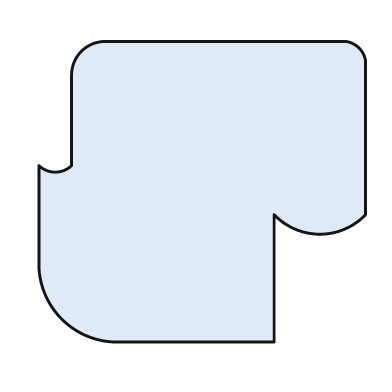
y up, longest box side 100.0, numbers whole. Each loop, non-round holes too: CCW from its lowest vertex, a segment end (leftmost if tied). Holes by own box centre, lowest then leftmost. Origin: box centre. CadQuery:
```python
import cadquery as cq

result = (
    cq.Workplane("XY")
    .moveTo(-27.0, -46.0)
    .lineTo(22.0, -46.0)
    .lineTo(22.0, -7.0)
    .threePointArc((36.0, -13.0), (50.0, -7.0))
    .lineTo(50.0, 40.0)
    .threePointArc((48.0, 44.0), (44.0, 46.0))
    .lineTo(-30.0, 46.0)
    .threePointArc((-37.0, 43.0), (-40.0, 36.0))
    .lineTo(-40.0, 8.0)
    .threePointArc((-45.0, 6.0), (-50.0, 8.0))
    .lineTo(-50.0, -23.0)
    .threePointArc((-43.0, -39.0), (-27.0, -46.0))
    .close()
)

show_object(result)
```